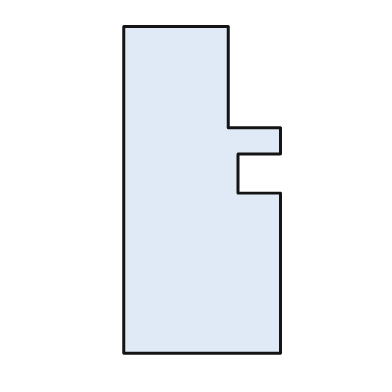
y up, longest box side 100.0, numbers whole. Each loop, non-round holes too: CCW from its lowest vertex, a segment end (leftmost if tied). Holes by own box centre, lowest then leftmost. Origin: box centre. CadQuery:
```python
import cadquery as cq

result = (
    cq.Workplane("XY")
    .moveTo(-24.0, -50.0)
    .lineTo(24.0, -50.0)
    .lineTo(24.0, -1.0)
    .lineTo(11.0, -1.0)
    .lineTo(11.0, 11.0)
    .lineTo(24.0, 11.0)
    .lineTo(24.0, 19.0)
    .lineTo(8.0, 19.0)
    .lineTo(8.0, 50.0)
    .lineTo(-24.0, 50.0)
    .close()
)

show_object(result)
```